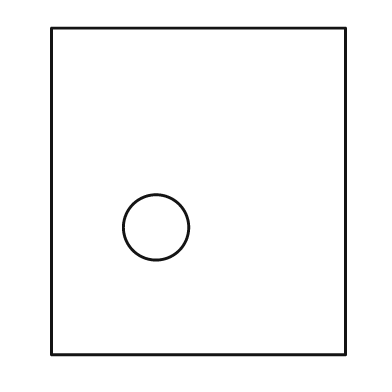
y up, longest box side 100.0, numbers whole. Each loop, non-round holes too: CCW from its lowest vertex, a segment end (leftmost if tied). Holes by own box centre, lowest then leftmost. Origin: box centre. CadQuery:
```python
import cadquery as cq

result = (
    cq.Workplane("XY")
    .moveTo(-45.0, -50.0)
    .lineTo(45.0, -50.0)
    .lineTo(45.0, 50.0)
    .lineTo(-45.0, 50.0)
    .close()
    .moveTo(-13.0, -11.0)
    .circle(10.0)
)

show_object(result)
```